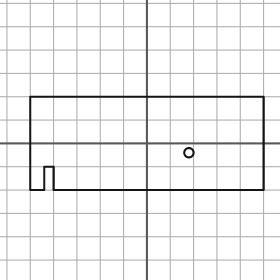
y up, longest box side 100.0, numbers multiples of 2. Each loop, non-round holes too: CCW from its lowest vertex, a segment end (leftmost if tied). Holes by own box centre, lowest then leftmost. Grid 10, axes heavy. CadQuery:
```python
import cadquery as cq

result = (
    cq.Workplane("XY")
    .moveTo(-50.0, -20.0)
    .lineTo(-44.0, -20.0)
    .lineTo(-44.0, -10.0)
    .lineTo(-40.0, -10.0)
    .lineTo(-40.0, -20.0)
    .lineTo(50.0, -20.0)
    .lineTo(50.0, 20.0)
    .lineTo(-50.0, 20.0)
    .close()
    .moveTo(18.0, -4.0)
    .circle(2.0)
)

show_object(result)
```